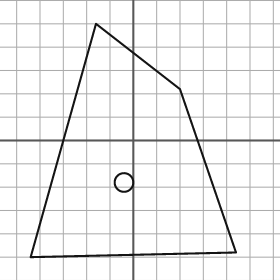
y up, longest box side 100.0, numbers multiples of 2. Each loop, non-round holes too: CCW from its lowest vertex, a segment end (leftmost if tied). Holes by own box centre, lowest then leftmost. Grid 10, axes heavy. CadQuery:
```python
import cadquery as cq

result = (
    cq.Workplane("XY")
    .moveTo(-44.0, -50.0)
    .lineTo(44.0, -48.0)
    .lineTo(20.0, 22.0)
    .lineTo(-16.0, 50.0)
    .close()
    .moveTo(-4.0, -18.0)
    .circle(4.0)
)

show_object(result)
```